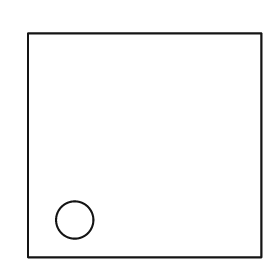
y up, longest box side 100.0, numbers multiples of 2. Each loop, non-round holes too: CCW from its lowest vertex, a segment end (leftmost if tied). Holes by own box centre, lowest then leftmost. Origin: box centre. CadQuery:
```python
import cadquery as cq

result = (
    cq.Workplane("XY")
    .moveTo(-50.0, -48.0)
    .lineTo(50.0, -48.0)
    .lineTo(50.0, 48.0)
    .lineTo(-50.0, 48.0)
    .close()
    .moveTo(-30.0, -32.0)
    .circle(8.0)
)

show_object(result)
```